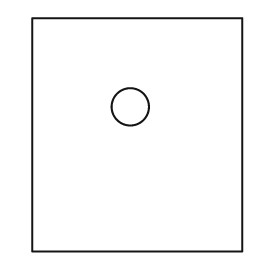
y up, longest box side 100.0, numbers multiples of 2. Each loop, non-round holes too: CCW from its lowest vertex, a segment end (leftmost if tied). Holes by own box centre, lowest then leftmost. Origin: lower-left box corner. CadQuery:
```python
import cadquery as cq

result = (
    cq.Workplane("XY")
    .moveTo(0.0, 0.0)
    .lineTo(90.0, 0.0)
    .lineTo(90.0, 100.0)
    .lineTo(0.0, 100.0)
    .close()
    .moveTo(42.0, 62.0)
    .circle(8.0)
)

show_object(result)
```